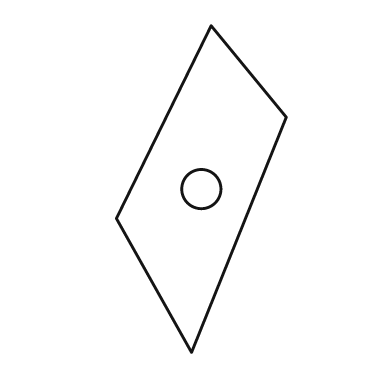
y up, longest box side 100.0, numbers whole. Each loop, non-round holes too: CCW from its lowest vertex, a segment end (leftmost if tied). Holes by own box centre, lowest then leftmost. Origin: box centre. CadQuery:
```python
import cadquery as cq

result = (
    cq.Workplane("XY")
    .moveTo(-3.0, -50.0)
    .lineTo(26.0, 22.0)
    .lineTo(3.0, 50.0)
    .lineTo(-26.0, -9.0)
    .close()
    .moveTo(0.0, 0.0)
    .circle(6.0)
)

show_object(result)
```